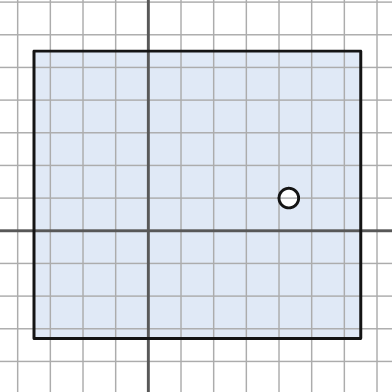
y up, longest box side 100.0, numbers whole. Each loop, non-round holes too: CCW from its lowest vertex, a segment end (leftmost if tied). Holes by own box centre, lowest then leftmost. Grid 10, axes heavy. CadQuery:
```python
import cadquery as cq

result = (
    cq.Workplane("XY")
    .moveTo(-35.0, -33.0)
    .lineTo(65.0, -33.0)
    .lineTo(65.0, 55.0)
    .lineTo(-35.0, 55.0)
    .close()
    .moveTo(43.0, 10.0)
    .circle(3.0)
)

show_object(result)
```